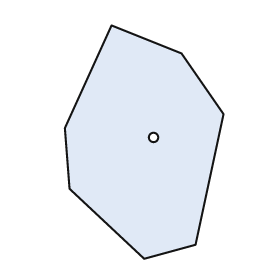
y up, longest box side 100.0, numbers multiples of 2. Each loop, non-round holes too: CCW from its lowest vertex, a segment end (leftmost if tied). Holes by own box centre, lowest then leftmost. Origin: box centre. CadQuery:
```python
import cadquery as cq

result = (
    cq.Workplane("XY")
    .moveTo(0.0, -50.0)
    .lineTo(22.0, -44.0)
    .lineTo(34.0, 12.0)
    .lineTo(16.0, 38.0)
    .lineTo(-14.0, 50.0)
    .lineTo(-34.0, 6.0)
    .lineTo(-32.0, -20.0)
    .close()
    .moveTo(4.0, 2.0)
    .circle(2.0)
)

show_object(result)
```